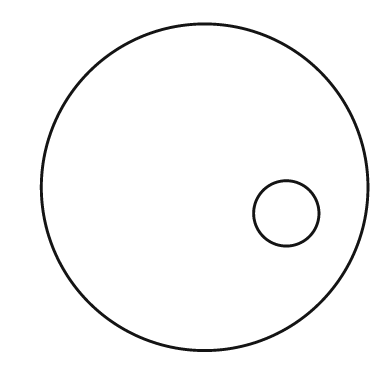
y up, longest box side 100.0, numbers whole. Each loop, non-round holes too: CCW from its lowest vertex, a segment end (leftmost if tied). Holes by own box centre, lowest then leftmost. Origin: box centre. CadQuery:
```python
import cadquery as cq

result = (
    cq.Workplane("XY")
    .moveTo(0.0, 0.0)
    .circle(50.0)
    .moveTo(25.0, -8.0)
    .circle(10.0)
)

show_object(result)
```